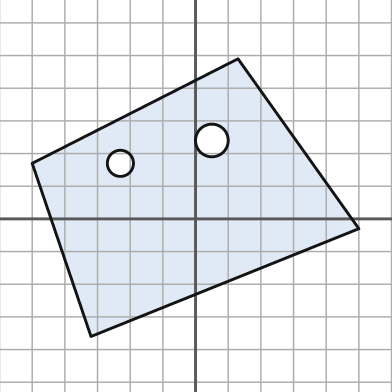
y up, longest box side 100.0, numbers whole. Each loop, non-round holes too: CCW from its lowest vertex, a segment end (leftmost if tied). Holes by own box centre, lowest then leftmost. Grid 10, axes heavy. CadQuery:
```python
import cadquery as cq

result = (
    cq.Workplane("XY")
    .moveTo(-32.0, -36.0)
    .lineTo(50.0, -3.0)
    .lineTo(13.0, 49.0)
    .lineTo(-50.0, 17.0)
    .close()
    .moveTo(-23.0, 17.0)
    .circle(4.0)
    .moveTo(5.0, 24.0)
    .circle(5.0)
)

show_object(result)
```